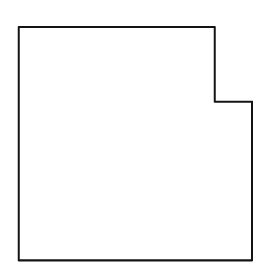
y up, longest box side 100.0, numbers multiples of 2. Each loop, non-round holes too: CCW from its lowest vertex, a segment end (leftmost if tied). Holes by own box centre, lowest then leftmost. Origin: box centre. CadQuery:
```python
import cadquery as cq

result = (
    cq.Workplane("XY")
    .moveTo(-50.0, -50.0)
    .lineTo(50.0, -50.0)
    .lineTo(50.0, 18.0)
    .lineTo(34.0, 18.0)
    .lineTo(34.0, 50.0)
    .lineTo(-50.0, 50.0)
    .close()
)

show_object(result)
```